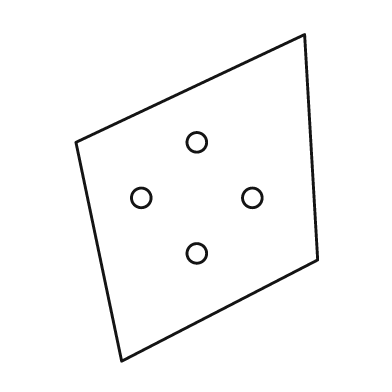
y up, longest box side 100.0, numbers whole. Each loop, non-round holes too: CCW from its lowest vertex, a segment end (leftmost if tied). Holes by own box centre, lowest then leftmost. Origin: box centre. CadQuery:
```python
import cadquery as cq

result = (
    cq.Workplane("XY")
    .moveTo(-23.0, -50.0)
    .lineTo(37.0, -19.0)
    .lineTo(33.0, 50.0)
    .lineTo(-37.0, 17.0)
    .close()
    .moveTo(0.0, -17.0)
    .circle(3.0)
    .moveTo(-17.0, 0.0)
    .circle(3.0)
    .moveTo(17.0, 0.0)
    .circle(3.0)
    .moveTo(0.0, 17.0)
    .circle(3.0)
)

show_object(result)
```